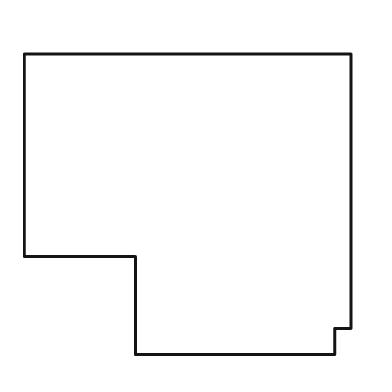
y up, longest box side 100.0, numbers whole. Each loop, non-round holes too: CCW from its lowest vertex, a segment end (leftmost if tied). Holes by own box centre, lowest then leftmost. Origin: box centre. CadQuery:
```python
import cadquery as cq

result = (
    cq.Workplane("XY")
    .moveTo(-16.0, -46.0)
    .lineTo(45.0, -46.0)
    .lineTo(45.0, -38.0)
    .lineTo(50.0, -38.0)
    .lineTo(50.0, 46.0)
    .lineTo(-50.0, 46.0)
    .lineTo(-50.0, -16.0)
    .lineTo(-16.0, -16.0)
    .close()
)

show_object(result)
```